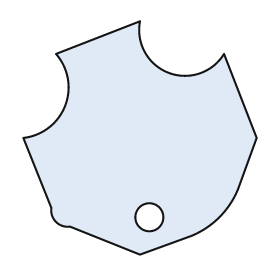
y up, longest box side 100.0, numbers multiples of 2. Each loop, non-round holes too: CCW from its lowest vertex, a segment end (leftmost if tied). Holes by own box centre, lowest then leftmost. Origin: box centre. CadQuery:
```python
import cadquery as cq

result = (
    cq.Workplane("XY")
    .moveTo(0.0, -50.0)
    .lineTo(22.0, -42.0)
    .threePointArc((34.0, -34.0), (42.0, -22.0))
    .lineTo(50.0, 0.0)
    .lineTo(36.0, 36.0)
    .threePointArc((12.0, 28.0), (0.0, 50.0))
    .lineTo(-36.0, 36.0)
    .threePointArc((-32.0, 14.0), (-50.0, 0.0))
    .lineTo(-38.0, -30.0)
    .threePointArc((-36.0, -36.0), (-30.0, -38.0))
    .close()
    .moveTo(4.0, -34.0)
    .circle(6.0)
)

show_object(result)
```